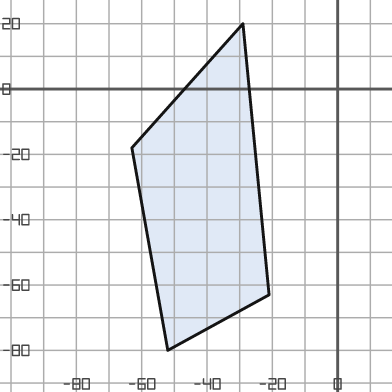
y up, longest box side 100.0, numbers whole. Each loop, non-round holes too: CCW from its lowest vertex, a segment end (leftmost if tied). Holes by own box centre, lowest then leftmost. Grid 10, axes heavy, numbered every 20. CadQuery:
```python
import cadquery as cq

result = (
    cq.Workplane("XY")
    .moveTo(-52.0, -80.0)
    .lineTo(-21.0, -63.0)
    .lineTo(-29.0, 20.0)
    .lineTo(-63.0, -18.0)
    .close()
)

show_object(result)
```